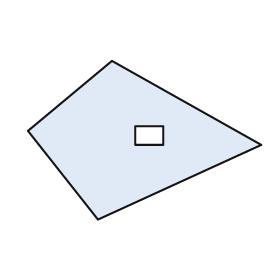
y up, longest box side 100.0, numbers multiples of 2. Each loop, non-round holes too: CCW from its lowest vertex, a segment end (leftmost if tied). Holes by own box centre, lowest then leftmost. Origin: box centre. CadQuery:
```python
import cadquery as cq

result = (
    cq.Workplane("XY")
    .moveTo(-20.0, -34.0)
    .lineTo(50.0, -2.0)
    .lineTo(-14.0, 34.0)
    .lineTo(-50.0, 4.0)
    .close()
    .moveTo(-4.0, -2.0)
    .lineTo(8.0, -2.0)
    .lineTo(8.0, 6.0)
    .lineTo(-4.0, 6.0)
    .close()
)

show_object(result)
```